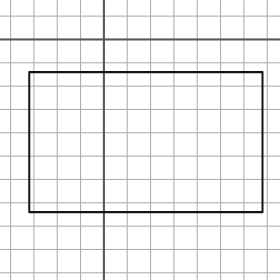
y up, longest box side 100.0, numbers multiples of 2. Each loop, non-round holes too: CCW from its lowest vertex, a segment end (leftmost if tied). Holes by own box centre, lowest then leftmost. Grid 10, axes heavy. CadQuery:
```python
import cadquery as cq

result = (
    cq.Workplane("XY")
    .moveTo(-32.0, -74.0)
    .lineTo(68.0, -74.0)
    .lineTo(68.0, -14.0)
    .lineTo(-32.0, -14.0)
    .close()
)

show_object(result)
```